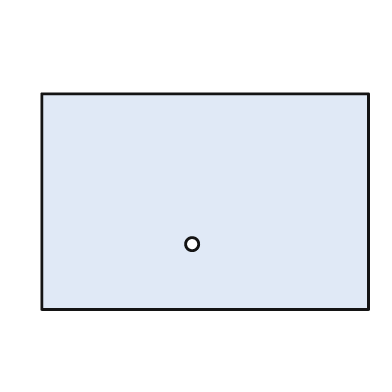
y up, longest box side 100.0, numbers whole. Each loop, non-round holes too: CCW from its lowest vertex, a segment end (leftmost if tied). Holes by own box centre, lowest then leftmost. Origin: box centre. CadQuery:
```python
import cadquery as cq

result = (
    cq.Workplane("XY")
    .moveTo(-50.0, -33.0)
    .lineTo(50.0, -33.0)
    .lineTo(50.0, 33.0)
    .lineTo(-50.0, 33.0)
    .close()
    .moveTo(-4.0, -13.0)
    .circle(2.0)
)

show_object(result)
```